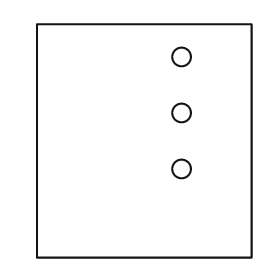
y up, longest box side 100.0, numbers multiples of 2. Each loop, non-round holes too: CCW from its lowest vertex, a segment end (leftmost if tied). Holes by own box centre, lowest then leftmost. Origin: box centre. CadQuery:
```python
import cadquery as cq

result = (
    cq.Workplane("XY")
    .moveTo(-46.0, -50.0)
    .lineTo(46.0, -50.0)
    .lineTo(46.0, 50.0)
    .lineTo(-46.0, 50.0)
    .close()
    .moveTo(16.0, -12.0)
    .circle(4.0)
    .moveTo(16.0, 12.0)
    .circle(4.0)
    .moveTo(16.0, 36.0)
    .circle(4.0)
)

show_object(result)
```